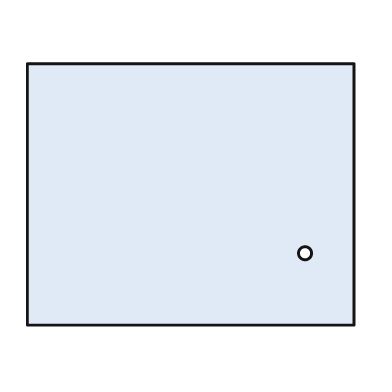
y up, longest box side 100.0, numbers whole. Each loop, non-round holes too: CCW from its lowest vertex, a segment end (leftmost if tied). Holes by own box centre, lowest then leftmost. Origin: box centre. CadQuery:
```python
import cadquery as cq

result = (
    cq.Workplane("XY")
    .moveTo(-50.0, -40.0)
    .lineTo(50.0, -40.0)
    .lineTo(50.0, 40.0)
    .lineTo(-50.0, 40.0)
    .close()
    .moveTo(35.0, -18.0)
    .circle(2.0)
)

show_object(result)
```